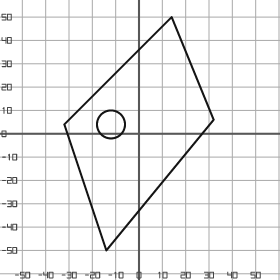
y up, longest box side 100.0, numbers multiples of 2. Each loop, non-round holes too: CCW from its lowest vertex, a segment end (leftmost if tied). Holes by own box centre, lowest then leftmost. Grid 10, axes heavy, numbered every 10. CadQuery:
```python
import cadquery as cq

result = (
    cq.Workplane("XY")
    .moveTo(-14.0, -50.0)
    .lineTo(32.0, 6.0)
    .lineTo(14.0, 50.0)
    .lineTo(-32.0, 4.0)
    .close()
    .moveTo(-12.0, 4.0)
    .circle(6.0)
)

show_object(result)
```